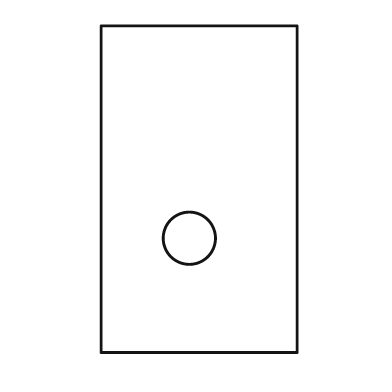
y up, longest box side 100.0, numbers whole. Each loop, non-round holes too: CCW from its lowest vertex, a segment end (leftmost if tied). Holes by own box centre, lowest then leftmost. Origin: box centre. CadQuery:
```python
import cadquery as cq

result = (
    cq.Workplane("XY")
    .moveTo(-30.0, -50.0)
    .lineTo(30.0, -50.0)
    .lineTo(30.0, 50.0)
    .lineTo(-30.0, 50.0)
    .close()
    .moveTo(-3.0, -15.0)
    .circle(8.0)
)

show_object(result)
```